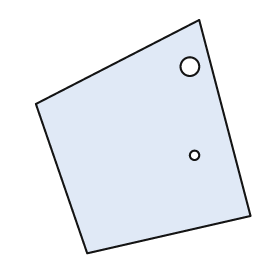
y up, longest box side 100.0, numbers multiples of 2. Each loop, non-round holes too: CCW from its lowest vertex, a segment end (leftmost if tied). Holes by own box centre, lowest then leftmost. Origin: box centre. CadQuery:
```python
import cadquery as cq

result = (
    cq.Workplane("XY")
    .moveTo(-24.0, -50.0)
    .lineTo(46.0, -34.0)
    .lineTo(24.0, 50.0)
    .lineTo(-46.0, 14.0)
    .close()
    .moveTo(22.0, -8.0)
    .circle(2.0)
    .moveTo(20.0, 30.0)
    .circle(4.0)
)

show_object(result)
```